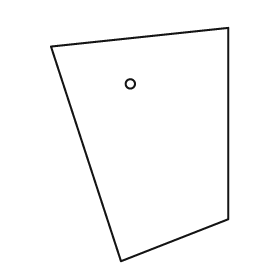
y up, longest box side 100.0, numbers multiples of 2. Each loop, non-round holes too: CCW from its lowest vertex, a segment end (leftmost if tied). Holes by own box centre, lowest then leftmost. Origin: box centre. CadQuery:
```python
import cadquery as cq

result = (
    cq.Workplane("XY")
    .moveTo(-8.0, -50.0)
    .lineTo(38.0, -32.0)
    .lineTo(38.0, 50.0)
    .lineTo(-38.0, 42.0)
    .close()
    .moveTo(-4.0, 26.0)
    .circle(2.0)
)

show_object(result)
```